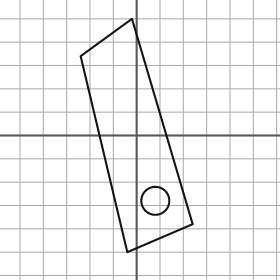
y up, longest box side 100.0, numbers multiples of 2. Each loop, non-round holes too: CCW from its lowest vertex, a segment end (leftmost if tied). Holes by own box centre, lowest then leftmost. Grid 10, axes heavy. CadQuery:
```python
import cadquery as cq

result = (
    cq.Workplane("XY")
    .moveTo(-4.0, -50.0)
    .lineTo(24.0, -38.0)
    .lineTo(-2.0, 50.0)
    .lineTo(-24.0, 34.0)
    .close()
    .moveTo(8.0, -28.0)
    .circle(6.0)
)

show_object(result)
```